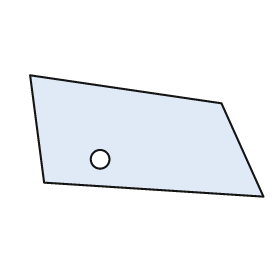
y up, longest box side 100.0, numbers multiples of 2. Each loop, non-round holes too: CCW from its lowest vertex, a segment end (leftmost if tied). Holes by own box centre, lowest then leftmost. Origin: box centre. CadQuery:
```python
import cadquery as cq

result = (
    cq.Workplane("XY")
    .moveTo(50.0, -26.0)
    .lineTo(32.0, 14.0)
    .lineTo(-50.0, 26.0)
    .lineTo(-44.0, -20.0)
    .close()
    .moveTo(-20.0, -10.0)
    .circle(4.0)
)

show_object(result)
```